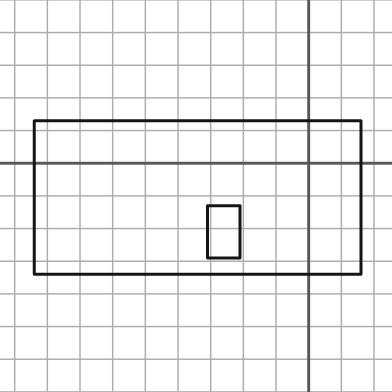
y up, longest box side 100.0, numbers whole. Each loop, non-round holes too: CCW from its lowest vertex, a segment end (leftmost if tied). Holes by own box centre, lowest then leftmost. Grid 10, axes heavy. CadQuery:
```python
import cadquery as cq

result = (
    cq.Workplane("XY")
    .moveTo(-84.0, -34.0)
    .lineTo(16.0, -34.0)
    .lineTo(16.0, 13.0)
    .lineTo(-84.0, 13.0)
    .close()
    .moveTo(-31.0, -29.0)
    .lineTo(-21.0, -29.0)
    .lineTo(-21.0, -13.0)
    .lineTo(-31.0, -13.0)
    .close()
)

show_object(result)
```